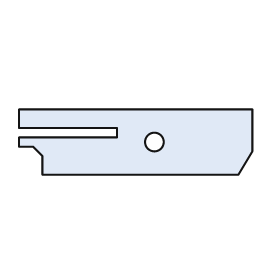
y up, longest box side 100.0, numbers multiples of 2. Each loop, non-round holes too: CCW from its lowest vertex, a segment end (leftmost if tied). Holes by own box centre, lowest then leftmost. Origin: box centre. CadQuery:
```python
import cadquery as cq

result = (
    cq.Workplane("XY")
    .moveTo(-40.0, -14.0)
    .lineTo(44.0, -14.0)
    .lineTo(50.0, -4.0)
    .lineTo(50.0, 14.0)
    .lineTo(-50.0, 14.0)
    .lineTo(-50.0, 6.0)
    .lineTo(-8.0, 6.0)
    .lineTo(-8.0, 2.0)
    .lineTo(-50.0, 2.0)
    .lineTo(-50.0, -2.0)
    .lineTo(-44.0, -2.0)
    .lineTo(-40.0, -6.0)
    .close()
    .moveTo(8.0, 0.0)
    .circle(4.0)
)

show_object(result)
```